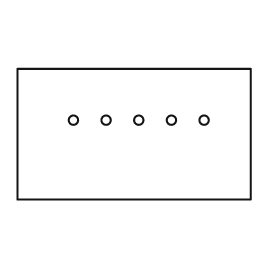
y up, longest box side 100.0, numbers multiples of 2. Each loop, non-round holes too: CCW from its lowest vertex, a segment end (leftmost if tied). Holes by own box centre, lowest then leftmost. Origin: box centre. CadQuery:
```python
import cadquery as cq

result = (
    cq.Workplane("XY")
    .moveTo(-50.0, -28.0)
    .lineTo(50.0, -28.0)
    .lineTo(50.0, 28.0)
    .lineTo(-50.0, 28.0)
    .close()
    .moveTo(-26.0, 6.0)
    .circle(2.0)
    .moveTo(-12.0, 6.0)
    .circle(2.0)
    .moveTo(2.0, 6.0)
    .circle(2.0)
    .moveTo(16.0, 6.0)
    .circle(2.0)
    .moveTo(30.0, 6.0)
    .circle(2.0)
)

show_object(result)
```